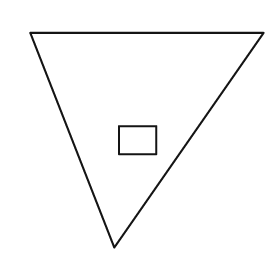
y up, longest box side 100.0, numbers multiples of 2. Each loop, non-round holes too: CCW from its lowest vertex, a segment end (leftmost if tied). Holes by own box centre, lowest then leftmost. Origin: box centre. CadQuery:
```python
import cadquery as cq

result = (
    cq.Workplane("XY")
    .moveTo(-14.0, -46.0)
    .lineTo(50.0, 46.0)
    .lineTo(-50.0, 46.0)
    .close()
    .moveTo(-12.0, -6.0)
    .lineTo(4.0, -6.0)
    .lineTo(4.0, 6.0)
    .lineTo(-12.0, 6.0)
    .close()
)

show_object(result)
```